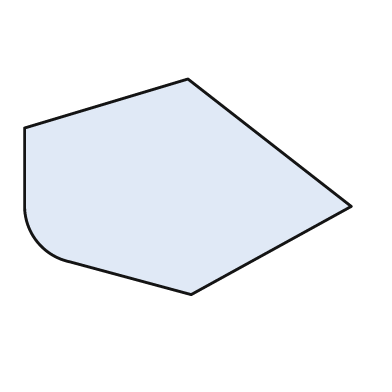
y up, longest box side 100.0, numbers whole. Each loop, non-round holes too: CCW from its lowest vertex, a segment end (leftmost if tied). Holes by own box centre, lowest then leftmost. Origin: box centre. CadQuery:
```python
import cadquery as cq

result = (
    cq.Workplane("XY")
    .moveTo(1.0, -33.0)
    .lineTo(50.0, -6.0)
    .lineTo(0.0, 33.0)
    .lineTo(-50.0, 18.0)
    .lineTo(-50.0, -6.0)
    .threePointArc((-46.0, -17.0), (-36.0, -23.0))
    .close()
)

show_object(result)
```